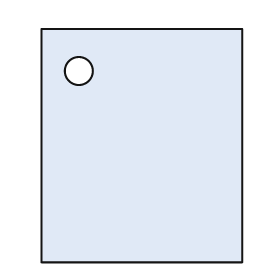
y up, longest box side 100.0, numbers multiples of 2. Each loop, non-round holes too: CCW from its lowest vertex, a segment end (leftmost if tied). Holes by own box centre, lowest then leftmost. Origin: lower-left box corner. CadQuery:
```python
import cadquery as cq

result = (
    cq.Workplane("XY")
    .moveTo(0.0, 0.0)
    .lineTo(86.0, 0.0)
    .lineTo(86.0, 100.0)
    .lineTo(0.0, 100.0)
    .close()
    .moveTo(16.0, 82.0)
    .circle(6.0)
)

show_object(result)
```